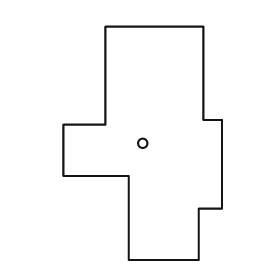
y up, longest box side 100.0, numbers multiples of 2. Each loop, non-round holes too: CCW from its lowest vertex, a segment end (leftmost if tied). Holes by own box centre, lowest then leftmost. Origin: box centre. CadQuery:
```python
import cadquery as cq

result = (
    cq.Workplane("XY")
    .moveTo(-6.0, -50.0)
    .lineTo(24.0, -50.0)
    .lineTo(24.0, -28.0)
    .lineTo(34.0, -28.0)
    .lineTo(34.0, 10.0)
    .lineTo(26.0, 10.0)
    .lineTo(26.0, 50.0)
    .lineTo(-16.0, 50.0)
    .lineTo(-16.0, 8.0)
    .lineTo(-34.0, 8.0)
    .lineTo(-34.0, -14.0)
    .lineTo(-6.0, -14.0)
    .close()
    .moveTo(0.0, 0.0)
    .circle(2.0)
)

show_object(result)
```